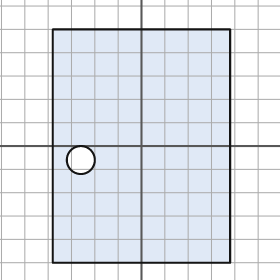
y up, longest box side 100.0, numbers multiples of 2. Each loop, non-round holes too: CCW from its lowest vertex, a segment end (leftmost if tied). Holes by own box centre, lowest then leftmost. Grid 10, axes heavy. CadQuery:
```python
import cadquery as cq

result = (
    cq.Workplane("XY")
    .moveTo(-38.0, -50.0)
    .lineTo(38.0, -50.0)
    .lineTo(38.0, 50.0)
    .lineTo(-38.0, 50.0)
    .close()
    .moveTo(-26.0, -6.0)
    .circle(6.0)
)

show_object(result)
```